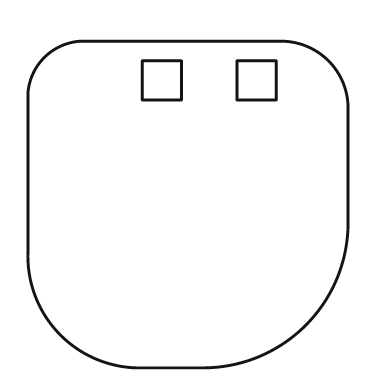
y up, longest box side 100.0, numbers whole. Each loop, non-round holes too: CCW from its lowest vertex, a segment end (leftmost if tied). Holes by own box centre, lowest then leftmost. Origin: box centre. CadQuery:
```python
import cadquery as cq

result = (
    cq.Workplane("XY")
    .moveTo(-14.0, -50.0)
    .lineTo(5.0, -50.0)
    .threePointArc((36.0, -37.0), (49.0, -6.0))
    .lineTo(49.0, 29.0)
    .threePointArc((43.0, 44.0), (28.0, 50.0))
    .lineTo(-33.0, 50.0)
    .threePointArc((-44.0, 45.0), (-49.0, 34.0))
    .lineTo(-49.0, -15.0)
    .threePointArc((-39.0, -40.0), (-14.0, -50.0))
    .close()
    .moveTo(-14.0, 32.0)
    .lineTo(-2.0, 32.0)
    .lineTo(-2.0, 44.0)
    .lineTo(-14.0, 44.0)
    .close()
    .moveTo(15.0, 32.0)
    .lineTo(27.0, 32.0)
    .lineTo(27.0, 44.0)
    .lineTo(15.0, 44.0)
    .close()
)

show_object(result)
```